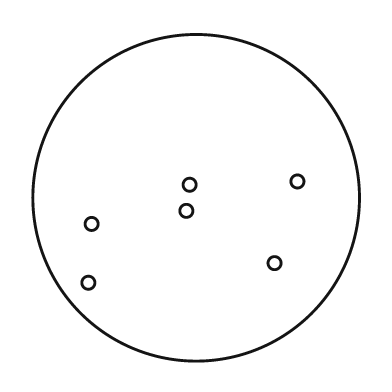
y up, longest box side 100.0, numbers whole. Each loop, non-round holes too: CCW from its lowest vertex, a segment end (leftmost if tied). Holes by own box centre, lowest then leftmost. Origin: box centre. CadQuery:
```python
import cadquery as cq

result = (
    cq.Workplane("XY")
    .moveTo(0.0, 0.0)
    .circle(50.0)
    .moveTo(-33.0, -26.0)
    .circle(2.0)
    .moveTo(24.0, -20.0)
    .circle(2.0)
    .moveTo(-32.0, -8.0)
    .circle(2.0)
    .moveTo(-3.0, -4.0)
    .circle(2.0)
    .moveTo(-2.0, 4.0)
    .circle(2.0)
    .moveTo(31.0, 5.0)
    .circle(2.0)
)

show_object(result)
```